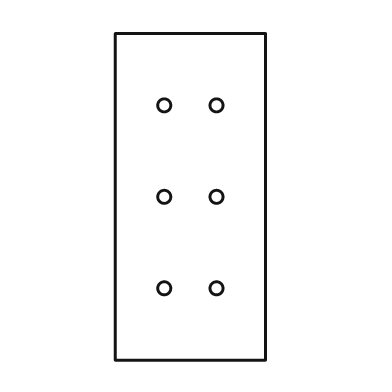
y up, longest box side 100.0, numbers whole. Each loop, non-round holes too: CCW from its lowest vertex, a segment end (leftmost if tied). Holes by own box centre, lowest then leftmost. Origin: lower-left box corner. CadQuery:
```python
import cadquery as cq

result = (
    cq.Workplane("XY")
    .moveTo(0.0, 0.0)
    .lineTo(46.0, 0.0)
    .lineTo(46.0, 100.0)
    .lineTo(0.0, 100.0)
    .close()
    .moveTo(15.0, 22.0)
    .circle(2.0)
    .moveTo(31.0, 22.0)
    .circle(2.0)
    .moveTo(15.0, 50.0)
    .circle(2.0)
    .moveTo(31.0, 50.0)
    .circle(2.0)
    .moveTo(15.0, 78.0)
    .circle(2.0)
    .moveTo(31.0, 78.0)
    .circle(2.0)
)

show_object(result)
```